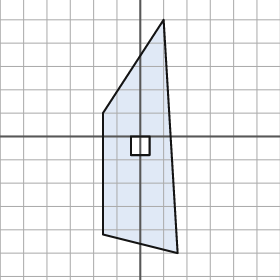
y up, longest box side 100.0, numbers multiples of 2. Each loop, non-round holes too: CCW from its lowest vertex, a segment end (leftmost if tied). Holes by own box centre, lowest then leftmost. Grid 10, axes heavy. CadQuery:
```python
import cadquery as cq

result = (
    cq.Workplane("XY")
    .moveTo(16.0, -50.0)
    .lineTo(10.0, 50.0)
    .lineTo(-16.0, 10.0)
    .lineTo(-16.0, -42.0)
    .close()
    .moveTo(-4.0, -8.0)
    .lineTo(4.0, -8.0)
    .lineTo(4.0, 0.0)
    .lineTo(-4.0, 0.0)
    .close()
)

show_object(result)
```